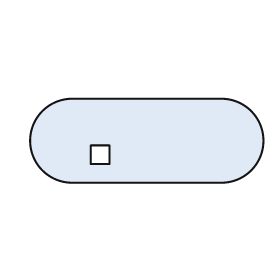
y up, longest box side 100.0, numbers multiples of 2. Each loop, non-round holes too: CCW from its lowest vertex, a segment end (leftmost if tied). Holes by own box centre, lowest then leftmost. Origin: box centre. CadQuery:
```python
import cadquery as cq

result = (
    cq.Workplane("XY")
    .moveTo(-32.0, -18.0)
    .lineTo(32.0, -18.0)
    .threePointArc((50.0, 0.0), (32.0, 18.0))
    .lineTo(-32.0, 18.0)
    .threePointArc((-50.0, 0.0), (-32.0, -18.0))
    .close()
    .moveTo(-24.0, -10.0)
    .lineTo(-16.0, -10.0)
    .lineTo(-16.0, -2.0)
    .lineTo(-24.0, -2.0)
    .close()
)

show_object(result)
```